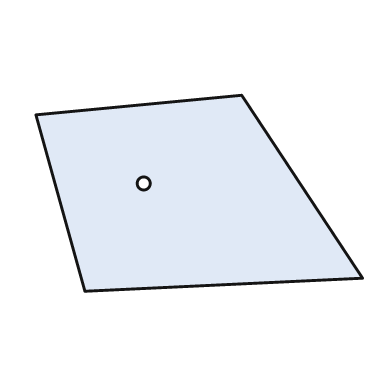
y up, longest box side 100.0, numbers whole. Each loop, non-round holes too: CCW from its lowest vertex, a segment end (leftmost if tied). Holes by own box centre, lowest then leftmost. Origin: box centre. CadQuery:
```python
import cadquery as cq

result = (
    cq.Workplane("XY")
    .moveTo(-35.0, -30.0)
    .lineTo(50.0, -26.0)
    .lineTo(13.0, 30.0)
    .lineTo(-50.0, 24.0)
    .close()
    .moveTo(-17.0, 3.0)
    .circle(2.0)
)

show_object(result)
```